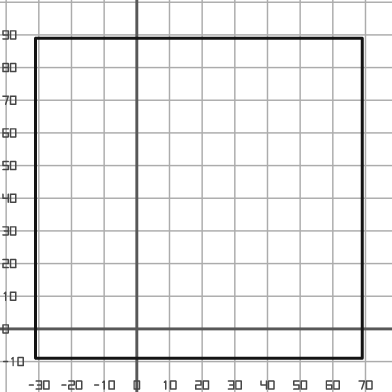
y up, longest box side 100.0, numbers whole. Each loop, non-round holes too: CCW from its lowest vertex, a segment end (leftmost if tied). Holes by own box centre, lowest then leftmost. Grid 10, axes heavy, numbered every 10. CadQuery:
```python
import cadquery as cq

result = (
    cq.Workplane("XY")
    .moveTo(-31.0, -9.0)
    .lineTo(69.0, -9.0)
    .lineTo(69.0, 89.0)
    .lineTo(-31.0, 89.0)
    .close()
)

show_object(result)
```